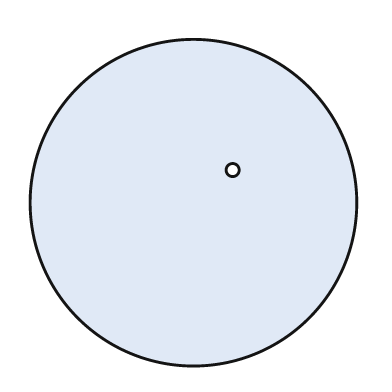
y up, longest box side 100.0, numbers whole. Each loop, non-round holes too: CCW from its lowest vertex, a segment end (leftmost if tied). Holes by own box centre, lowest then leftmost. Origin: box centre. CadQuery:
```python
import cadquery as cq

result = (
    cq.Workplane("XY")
    .moveTo(0.0, 0.0)
    .circle(50.0)
    .moveTo(12.0, 10.0)
    .circle(2.0)
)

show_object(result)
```